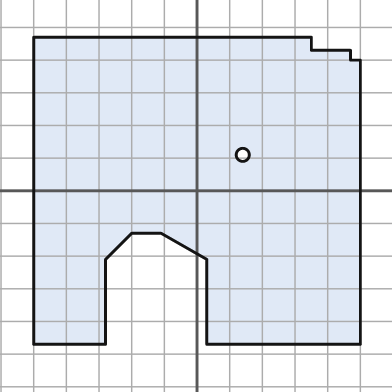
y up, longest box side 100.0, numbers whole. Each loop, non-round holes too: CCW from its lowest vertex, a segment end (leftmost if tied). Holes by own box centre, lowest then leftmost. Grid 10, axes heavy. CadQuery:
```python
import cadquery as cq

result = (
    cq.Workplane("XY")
    .moveTo(-50.0, -47.0)
    .lineTo(-28.0, -47.0)
    .lineTo(-28.0, -21.0)
    .lineTo(-20.0, -13.0)
    .lineTo(-11.0, -13.0)
    .lineTo(3.0, -21.0)
    .lineTo(3.0, -47.0)
    .lineTo(50.0, -47.0)
    .lineTo(50.0, 40.0)
    .lineTo(47.0, 40.0)
    .lineTo(47.0, 43.0)
    .lineTo(35.0, 43.0)
    .lineTo(35.0, 47.0)
    .lineTo(-50.0, 47.0)
    .close()
    .moveTo(14.0, 11.0)
    .circle(2.0)
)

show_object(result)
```